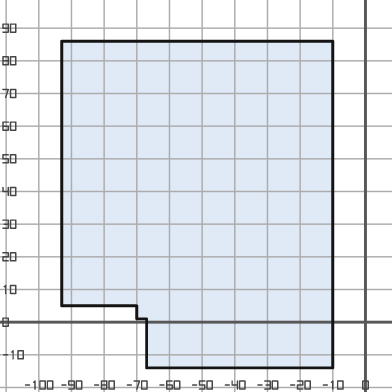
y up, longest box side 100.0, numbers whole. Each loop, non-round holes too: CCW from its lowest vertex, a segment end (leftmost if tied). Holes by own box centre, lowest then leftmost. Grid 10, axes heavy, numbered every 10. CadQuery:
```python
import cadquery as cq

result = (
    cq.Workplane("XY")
    .moveTo(-67.0, -14.0)
    .lineTo(-10.0, -14.0)
    .lineTo(-10.0, 86.0)
    .lineTo(-93.0, 86.0)
    .lineTo(-93.0, 5.0)
    .lineTo(-70.0, 5.0)
    .lineTo(-70.0, 1.0)
    .lineTo(-67.0, 1.0)
    .close()
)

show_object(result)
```